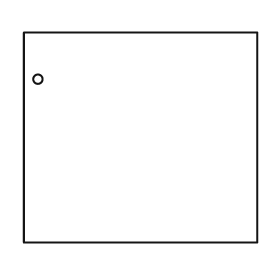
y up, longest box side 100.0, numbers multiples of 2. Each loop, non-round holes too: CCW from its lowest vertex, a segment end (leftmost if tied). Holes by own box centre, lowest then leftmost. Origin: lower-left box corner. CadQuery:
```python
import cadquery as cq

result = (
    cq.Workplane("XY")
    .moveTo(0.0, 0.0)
    .lineTo(100.0, 0.0)
    .lineTo(100.0, 90.0)
    .lineTo(0.0, 90.0)
    .close()
    .moveTo(6.0, 70.0)
    .circle(2.0)
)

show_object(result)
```